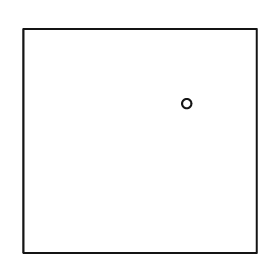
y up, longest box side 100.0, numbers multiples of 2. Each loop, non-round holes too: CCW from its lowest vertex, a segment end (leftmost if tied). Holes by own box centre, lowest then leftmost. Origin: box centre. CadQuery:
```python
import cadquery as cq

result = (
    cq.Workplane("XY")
    .moveTo(-50.0, -48.0)
    .lineTo(50.0, -48.0)
    .lineTo(50.0, 48.0)
    .lineTo(-50.0, 48.0)
    .close()
    .moveTo(20.0, 16.0)
    .circle(2.0)
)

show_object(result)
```